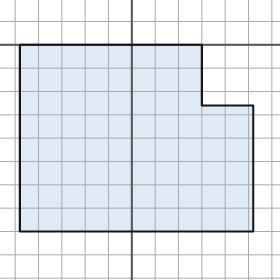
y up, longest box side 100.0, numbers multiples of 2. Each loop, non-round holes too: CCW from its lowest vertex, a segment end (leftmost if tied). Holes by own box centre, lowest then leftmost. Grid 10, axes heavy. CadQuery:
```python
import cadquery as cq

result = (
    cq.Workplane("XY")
    .moveTo(-48.0, -80.0)
    .lineTo(52.0, -80.0)
    .lineTo(52.0, -26.0)
    .lineTo(30.0, -26.0)
    .lineTo(30.0, 0.0)
    .lineTo(-48.0, 0.0)
    .close()
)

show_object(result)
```